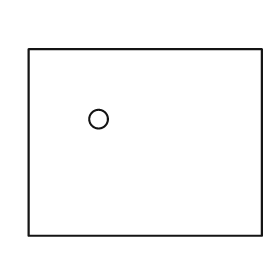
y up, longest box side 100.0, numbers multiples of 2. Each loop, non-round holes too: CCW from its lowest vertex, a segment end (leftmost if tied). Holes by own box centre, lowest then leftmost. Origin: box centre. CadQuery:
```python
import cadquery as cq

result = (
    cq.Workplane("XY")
    .moveTo(-50.0, -40.0)
    .lineTo(50.0, -40.0)
    .lineTo(50.0, 40.0)
    .lineTo(-50.0, 40.0)
    .close()
    .moveTo(-20.0, 10.0)
    .circle(4.0)
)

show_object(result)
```